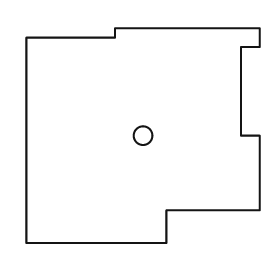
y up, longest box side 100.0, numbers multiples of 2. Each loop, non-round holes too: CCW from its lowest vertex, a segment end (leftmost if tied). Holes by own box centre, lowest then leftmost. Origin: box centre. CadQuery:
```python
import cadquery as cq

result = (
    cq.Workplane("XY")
    .moveTo(-50.0, -46.0)
    .lineTo(10.0, -46.0)
    .lineTo(10.0, -32.0)
    .lineTo(50.0, -32.0)
    .lineTo(50.0, 0.0)
    .lineTo(42.0, 0.0)
    .lineTo(42.0, 38.0)
    .lineTo(50.0, 38.0)
    .lineTo(50.0, 46.0)
    .lineTo(-12.0, 46.0)
    .lineTo(-12.0, 42.0)
    .lineTo(-50.0, 42.0)
    .close()
    .moveTo(0.0, 0.0)
    .circle(4.0)
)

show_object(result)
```